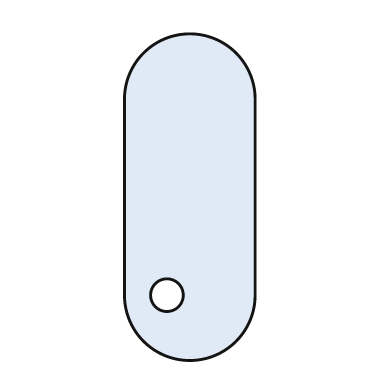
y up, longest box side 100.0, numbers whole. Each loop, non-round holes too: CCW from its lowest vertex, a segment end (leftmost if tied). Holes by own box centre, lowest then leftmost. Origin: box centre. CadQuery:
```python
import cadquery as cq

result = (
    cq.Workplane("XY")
    .moveTo(-20.0, -30.0)
    .threePointArc((0.0, -50.0), (20.0, -30.0))
    .lineTo(20.0, 30.0)
    .threePointArc((0.0, 50.0), (-20.0, 30.0))
    .close()
    .moveTo(-7.0, -30.0)
    .circle(5.0)
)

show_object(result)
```